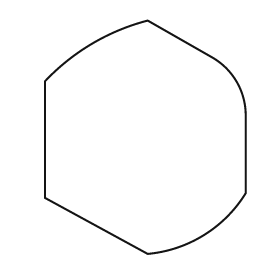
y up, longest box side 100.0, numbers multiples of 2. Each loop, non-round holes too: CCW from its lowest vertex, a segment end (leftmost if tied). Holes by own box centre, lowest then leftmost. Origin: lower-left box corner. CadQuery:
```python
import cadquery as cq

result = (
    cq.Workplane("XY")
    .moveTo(44.0, 0.0)
    .threePointArc((68.0, 8.0), (86.0, 26.0))
    .lineTo(86.0, 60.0)
    .threePointArc((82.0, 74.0), (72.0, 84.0))
    .lineTo(44.0, 100.0)
    .threePointArc((20.0, 90.0), (0.0, 74.0))
    .lineTo(0.0, 24.0)
    .close()
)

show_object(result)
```